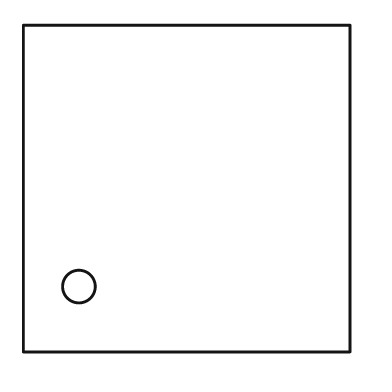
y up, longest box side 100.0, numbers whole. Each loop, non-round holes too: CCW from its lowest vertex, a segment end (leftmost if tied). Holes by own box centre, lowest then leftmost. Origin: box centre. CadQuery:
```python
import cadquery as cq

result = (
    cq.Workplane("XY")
    .moveTo(-50.0, -50.0)
    .lineTo(50.0, -50.0)
    .lineTo(50.0, 50.0)
    .lineTo(-50.0, 50.0)
    .close()
    .moveTo(-33.0, -30.0)
    .circle(5.0)
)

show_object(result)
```